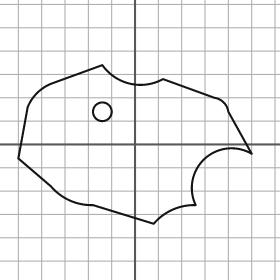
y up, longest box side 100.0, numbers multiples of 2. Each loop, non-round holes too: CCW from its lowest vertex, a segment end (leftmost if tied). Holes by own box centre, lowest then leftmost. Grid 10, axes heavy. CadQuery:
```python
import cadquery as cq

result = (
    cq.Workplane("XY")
    .moveTo(8.0, -34.0)
    .threePointArc((16.0, -28.0), (26.0, -26.0))
    .threePointArc((30.0, -6.0), (50.0, -4.0))
    .lineTo(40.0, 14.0)
    .threePointArc((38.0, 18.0), (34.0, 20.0))
    .lineTo(12.0, 28.0)
    .threePointArc((-2.0, 26.0), (-14.0, 34.0))
    .lineTo(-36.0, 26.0)
    .threePointArc((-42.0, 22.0), (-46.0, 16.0))
    .lineTo(-50.0, -6.0)
    .lineTo(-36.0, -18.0)
    .threePointArc((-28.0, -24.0), (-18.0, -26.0))
    .close()
    .moveTo(-14.0, 14.0)
    .circle(4.0)
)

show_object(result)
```